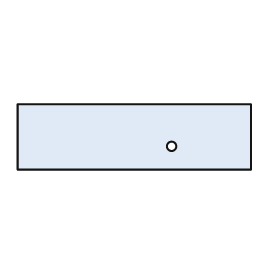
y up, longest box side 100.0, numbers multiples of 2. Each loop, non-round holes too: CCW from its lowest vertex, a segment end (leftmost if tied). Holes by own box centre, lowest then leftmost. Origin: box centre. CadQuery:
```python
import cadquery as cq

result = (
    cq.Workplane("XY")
    .moveTo(-50.0, -14.0)
    .lineTo(50.0, -14.0)
    .lineTo(50.0, 14.0)
    .lineTo(-50.0, 14.0)
    .close()
    .moveTo(16.0, -4.0)
    .circle(2.0)
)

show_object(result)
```